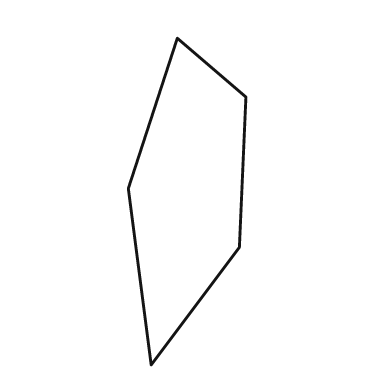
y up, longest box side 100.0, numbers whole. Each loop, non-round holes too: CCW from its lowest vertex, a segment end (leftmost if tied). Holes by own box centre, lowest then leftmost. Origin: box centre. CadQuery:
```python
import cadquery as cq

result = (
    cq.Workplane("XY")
    .moveTo(-11.0, -50.0)
    .lineTo(16.0, -14.0)
    .lineTo(18.0, 32.0)
    .lineTo(-3.0, 50.0)
    .lineTo(-18.0, 4.0)
    .close()
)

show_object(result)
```